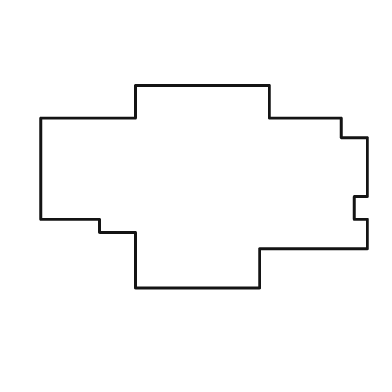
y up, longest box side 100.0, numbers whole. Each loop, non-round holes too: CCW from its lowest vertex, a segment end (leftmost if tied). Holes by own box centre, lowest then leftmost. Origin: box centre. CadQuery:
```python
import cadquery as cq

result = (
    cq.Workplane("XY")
    .moveTo(-21.0, -31.0)
    .lineTo(17.0, -31.0)
    .lineTo(17.0, -19.0)
    .lineTo(50.0, -19.0)
    .lineTo(50.0, -10.0)
    .lineTo(46.0, -10.0)
    .lineTo(46.0, -3.0)
    .lineTo(50.0, -3.0)
    .lineTo(50.0, 15.0)
    .lineTo(42.0, 15.0)
    .lineTo(42.0, 21.0)
    .lineTo(20.0, 21.0)
    .lineTo(20.0, 31.0)
    .lineTo(-21.0, 31.0)
    .lineTo(-21.0, 21.0)
    .lineTo(-50.0, 21.0)
    .lineTo(-50.0, -10.0)
    .lineTo(-32.0, -10.0)
    .lineTo(-32.0, -14.0)
    .lineTo(-21.0, -14.0)
    .close()
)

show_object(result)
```